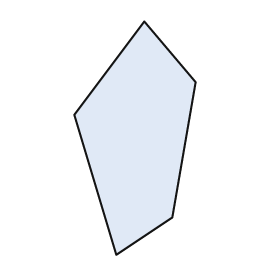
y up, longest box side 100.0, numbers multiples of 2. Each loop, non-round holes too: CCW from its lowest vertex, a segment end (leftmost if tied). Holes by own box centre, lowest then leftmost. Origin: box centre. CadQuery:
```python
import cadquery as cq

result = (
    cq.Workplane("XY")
    .moveTo(-8.0, -50.0)
    .lineTo(16.0, -34.0)
    .lineTo(26.0, 24.0)
    .lineTo(4.0, 50.0)
    .lineTo(-26.0, 10.0)
    .close()
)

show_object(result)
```